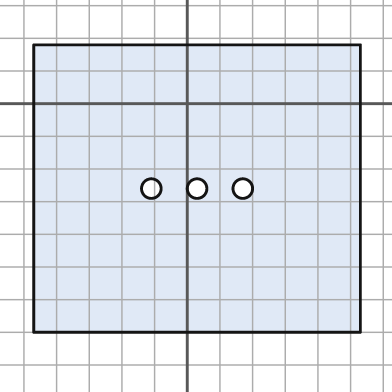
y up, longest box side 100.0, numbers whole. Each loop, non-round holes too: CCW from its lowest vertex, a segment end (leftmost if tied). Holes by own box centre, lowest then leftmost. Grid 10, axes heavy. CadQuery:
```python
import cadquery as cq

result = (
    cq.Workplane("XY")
    .moveTo(-47.0, -70.0)
    .lineTo(53.0, -70.0)
    .lineTo(53.0, 18.0)
    .lineTo(-47.0, 18.0)
    .close()
    .moveTo(-11.0, -26.0)
    .circle(3.0)
    .moveTo(3.0, -26.0)
    .circle(3.0)
    .moveTo(17.0, -26.0)
    .circle(3.0)
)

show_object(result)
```